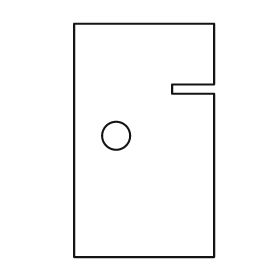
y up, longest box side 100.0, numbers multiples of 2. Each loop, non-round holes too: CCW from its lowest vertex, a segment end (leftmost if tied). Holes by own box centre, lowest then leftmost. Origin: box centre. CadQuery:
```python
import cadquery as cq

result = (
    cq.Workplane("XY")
    .moveTo(-30.0, -50.0)
    .lineTo(30.0, -50.0)
    .lineTo(30.0, 20.0)
    .lineTo(12.0, 20.0)
    .lineTo(12.0, 24.0)
    .lineTo(30.0, 24.0)
    .lineTo(30.0, 50.0)
    .lineTo(-30.0, 50.0)
    .close()
    .moveTo(-12.0, 2.0)
    .circle(6.0)
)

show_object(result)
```